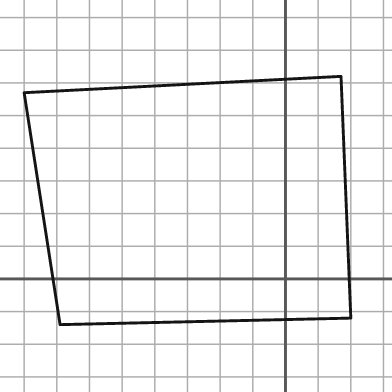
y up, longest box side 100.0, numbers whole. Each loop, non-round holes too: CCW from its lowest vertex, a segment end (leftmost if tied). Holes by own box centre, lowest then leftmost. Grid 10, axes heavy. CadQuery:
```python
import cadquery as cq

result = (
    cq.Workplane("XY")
    .moveTo(-69.0, -14.0)
    .lineTo(20.0, -12.0)
    .lineTo(17.0, 62.0)
    .lineTo(-80.0, 57.0)
    .close()
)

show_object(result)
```